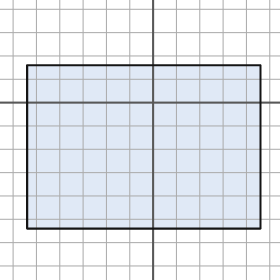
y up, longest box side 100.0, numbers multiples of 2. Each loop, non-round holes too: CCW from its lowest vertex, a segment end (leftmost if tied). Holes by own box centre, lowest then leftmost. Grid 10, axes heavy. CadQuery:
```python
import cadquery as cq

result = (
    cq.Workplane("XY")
    .moveTo(-54.0, -54.0)
    .lineTo(46.0, -54.0)
    .lineTo(46.0, 16.0)
    .lineTo(-54.0, 16.0)
    .close()
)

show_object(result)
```